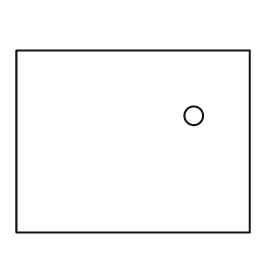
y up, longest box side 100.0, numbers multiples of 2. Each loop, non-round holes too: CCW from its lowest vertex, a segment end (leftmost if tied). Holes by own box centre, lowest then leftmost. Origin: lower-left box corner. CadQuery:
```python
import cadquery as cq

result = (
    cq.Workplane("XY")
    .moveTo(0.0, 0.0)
    .lineTo(100.0, 0.0)
    .lineTo(100.0, 78.0)
    .lineTo(0.0, 78.0)
    .close()
    .moveTo(76.0, 50.0)
    .circle(4.0)
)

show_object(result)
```